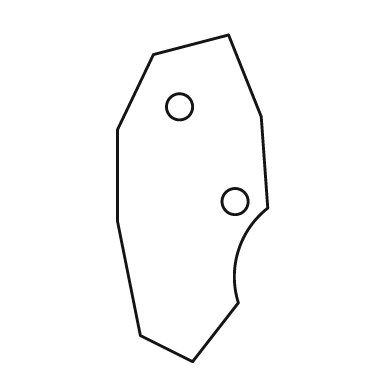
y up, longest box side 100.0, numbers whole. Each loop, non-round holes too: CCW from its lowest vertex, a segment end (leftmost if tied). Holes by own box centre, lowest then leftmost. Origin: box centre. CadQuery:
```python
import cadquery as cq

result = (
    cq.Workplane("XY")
    .moveTo(0.0, -50.0)
    .lineTo(14.0, -32.0)
    .threePointArc((14.0, -16.0), (23.0, -3.0))
    .lineTo(21.0, 25.0)
    .lineTo(11.0, 50.0)
    .lineTo(-12.0, 44.0)
    .lineTo(-23.0, 21.0)
    .lineTo(-23.0, -7.0)
    .lineTo(-16.0, -42.0)
    .close()
    .moveTo(13.0, -1.0)
    .circle(4.0)
    .moveTo(-4.0, 28.0)
    .circle(4.0)
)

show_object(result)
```